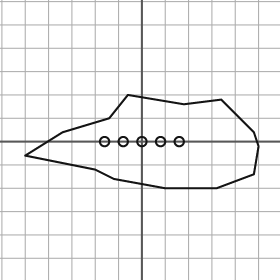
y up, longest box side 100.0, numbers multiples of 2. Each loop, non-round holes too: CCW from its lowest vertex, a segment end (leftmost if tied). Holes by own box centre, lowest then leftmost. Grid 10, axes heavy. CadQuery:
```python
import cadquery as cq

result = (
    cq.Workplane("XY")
    .moveTo(10.0, -20.0)
    .lineTo(32.0, -20.0)
    .lineTo(48.0, -14.0)
    .lineTo(50.0, -2.0)
    .lineTo(48.0, 4.0)
    .lineTo(34.0, 18.0)
    .lineTo(18.0, 16.0)
    .lineTo(-6.0, 20.0)
    .lineTo(-14.0, 10.0)
    .lineTo(-34.0, 4.0)
    .lineTo(-50.0, -6.0)
    .lineTo(-20.0, -12.0)
    .lineTo(-12.0, -16.0)
    .close()
    .moveTo(-16.0, 0.0)
    .circle(2.0)
    .moveTo(-8.0, 0.0)
    .circle(2.0)
    .moveTo(0.0, 0.0)
    .circle(2.0)
    .moveTo(8.0, 0.0)
    .circle(2.0)
    .moveTo(16.0, 0.0)
    .circle(2.0)
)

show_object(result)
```